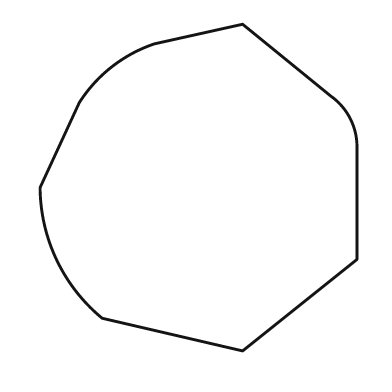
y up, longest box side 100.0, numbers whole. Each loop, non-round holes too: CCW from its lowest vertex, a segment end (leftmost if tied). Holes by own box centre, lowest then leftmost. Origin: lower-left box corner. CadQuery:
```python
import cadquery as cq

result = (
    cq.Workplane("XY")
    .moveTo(62.0, 0.0)
    .lineTo(97.0, 28.0)
    .lineTo(97.0, 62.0)
    .threePointArc((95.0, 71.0), (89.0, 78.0))
    .lineTo(62.0, 100.0)
    .lineTo(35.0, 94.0)
    .threePointArc((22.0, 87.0), (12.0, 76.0))
    .lineTo(0.0, 50.0)
    .threePointArc((5.0, 28.0), (19.0, 10.0))
    .close()
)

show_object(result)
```